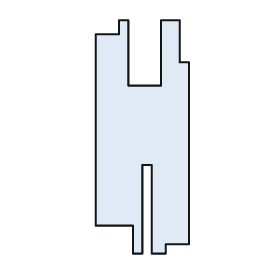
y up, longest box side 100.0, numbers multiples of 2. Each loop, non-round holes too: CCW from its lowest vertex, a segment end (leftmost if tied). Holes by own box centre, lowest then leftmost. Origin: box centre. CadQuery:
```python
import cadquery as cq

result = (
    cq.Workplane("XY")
    .moveTo(-4.0, -50.0)
    .lineTo(0.0, -50.0)
    .lineTo(0.0, -12.0)
    .lineTo(4.0, -12.0)
    .lineTo(4.0, -50.0)
    .lineTo(10.0, -50.0)
    .lineTo(10.0, -46.0)
    .lineTo(20.0, -46.0)
    .lineTo(20.0, 32.0)
    .lineTo(16.0, 32.0)
    .lineTo(16.0, 50.0)
    .lineTo(8.0, 50.0)
    .lineTo(8.0, 22.0)
    .lineTo(-6.0, 22.0)
    .lineTo(-6.0, 50.0)
    .lineTo(-10.0, 50.0)
    .lineTo(-10.0, 44.0)
    .lineTo(-20.0, 44.0)
    .lineTo(-20.0, -38.0)
    .lineTo(-4.0, -38.0)
    .close()
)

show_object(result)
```